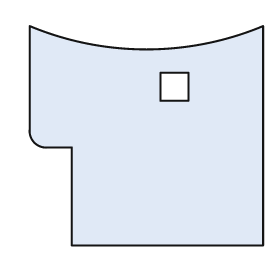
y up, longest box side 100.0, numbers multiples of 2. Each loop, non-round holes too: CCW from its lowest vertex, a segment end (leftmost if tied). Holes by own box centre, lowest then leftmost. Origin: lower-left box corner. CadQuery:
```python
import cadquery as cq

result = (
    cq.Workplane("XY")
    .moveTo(18.0, 0.0)
    .lineTo(100.0, 0.0)
    .lineTo(100.0, 94.0)
    .threePointArc((50.0, 84.0), (0.0, 94.0))
    .lineTo(0.0, 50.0)
    .threePointArc((2.0, 44.0), (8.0, 42.0))
    .lineTo(18.0, 42.0)
    .close()
    .moveTo(56.0, 62.0)
    .lineTo(68.0, 62.0)
    .lineTo(68.0, 74.0)
    .lineTo(56.0, 74.0)
    .close()
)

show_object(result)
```